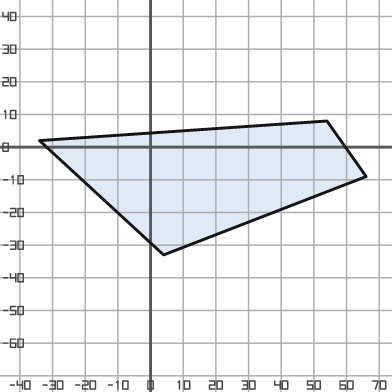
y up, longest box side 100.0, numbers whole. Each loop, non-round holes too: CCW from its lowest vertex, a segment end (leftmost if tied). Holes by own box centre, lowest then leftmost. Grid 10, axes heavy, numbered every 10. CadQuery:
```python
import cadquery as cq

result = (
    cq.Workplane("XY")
    .moveTo(4.0, -33.0)
    .lineTo(66.0, -9.0)
    .lineTo(54.0, 8.0)
    .lineTo(-34.0, 2.0)
    .close()
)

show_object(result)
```